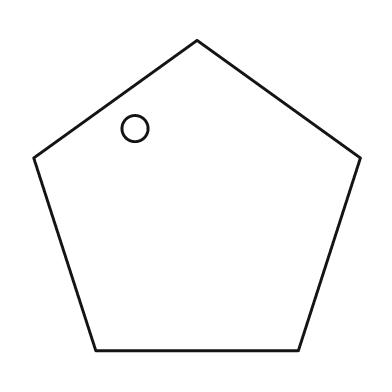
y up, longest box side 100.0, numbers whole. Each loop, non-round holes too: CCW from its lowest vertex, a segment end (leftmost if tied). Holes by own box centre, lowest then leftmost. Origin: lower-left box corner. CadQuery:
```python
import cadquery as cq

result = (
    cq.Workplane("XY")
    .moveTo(19.0, 0.0)
    .lineTo(81.0, 0.0)
    .lineTo(100.0, 59.0)
    .lineTo(50.0, 95.0)
    .lineTo(0.0, 59.0)
    .close()
    .moveTo(31.0, 68.0)
    .circle(4.0)
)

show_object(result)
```